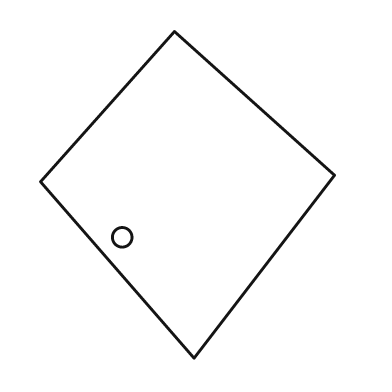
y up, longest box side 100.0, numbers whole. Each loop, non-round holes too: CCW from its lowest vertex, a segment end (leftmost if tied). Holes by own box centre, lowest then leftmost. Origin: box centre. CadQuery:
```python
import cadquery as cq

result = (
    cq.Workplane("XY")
    .moveTo(2.0, -50.0)
    .lineTo(45.0, 6.0)
    .lineTo(-4.0, 50.0)
    .lineTo(-45.0, 4.0)
    .close()
    .moveTo(-20.0, -13.0)
    .circle(3.0)
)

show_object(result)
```